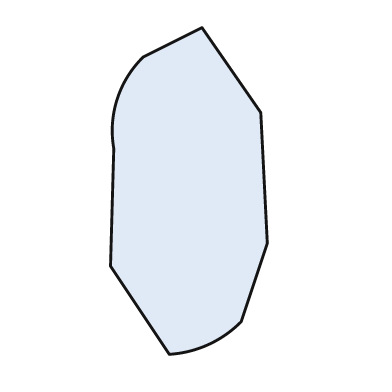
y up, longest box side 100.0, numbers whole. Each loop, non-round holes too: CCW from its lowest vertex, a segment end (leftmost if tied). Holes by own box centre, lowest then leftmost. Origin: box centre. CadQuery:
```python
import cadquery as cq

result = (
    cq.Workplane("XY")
    .moveTo(-6.0, -50.0)
    .threePointArc((6.0, -47.0), (16.0, -40.0))
    .lineTo(24.0, -16.0)
    .lineTo(22.0, 24.0)
    .lineTo(4.0, 50.0)
    .lineTo(-14.0, 41.0)
    .threePointArc((-22.0, 28.0), (-23.0, 13.0))
    .lineTo(-24.0, -23.0)
    .close()
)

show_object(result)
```